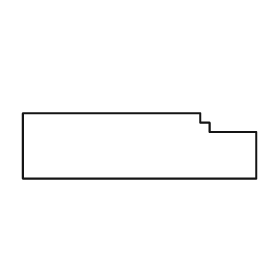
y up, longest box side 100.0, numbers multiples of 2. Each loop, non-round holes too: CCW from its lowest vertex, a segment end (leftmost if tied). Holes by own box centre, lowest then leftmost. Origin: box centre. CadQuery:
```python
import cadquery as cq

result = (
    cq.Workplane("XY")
    .moveTo(-50.0, -14.0)
    .lineTo(50.0, -14.0)
    .lineTo(50.0, 6.0)
    .lineTo(30.0, 6.0)
    .lineTo(30.0, 10.0)
    .lineTo(26.0, 10.0)
    .lineTo(26.0, 14.0)
    .lineTo(-50.0, 14.0)
    .close()
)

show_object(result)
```